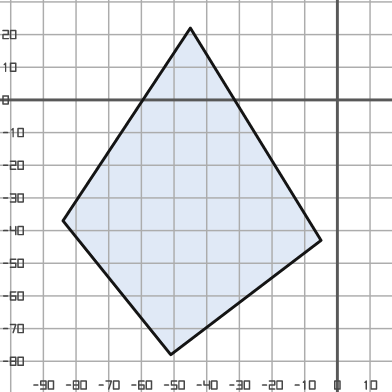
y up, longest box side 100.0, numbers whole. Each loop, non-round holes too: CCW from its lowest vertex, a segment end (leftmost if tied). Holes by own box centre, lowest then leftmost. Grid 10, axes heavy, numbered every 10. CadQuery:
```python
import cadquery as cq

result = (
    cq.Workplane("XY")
    .moveTo(-51.0, -78.0)
    .lineTo(-5.0, -43.0)
    .lineTo(-45.0, 22.0)
    .lineTo(-84.0, -37.0)
    .close()
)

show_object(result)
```